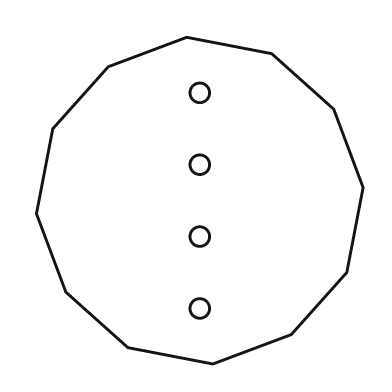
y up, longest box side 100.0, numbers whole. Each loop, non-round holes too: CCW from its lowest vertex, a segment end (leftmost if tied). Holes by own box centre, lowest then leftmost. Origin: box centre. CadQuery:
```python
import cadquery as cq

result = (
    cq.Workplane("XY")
    .moveTo(4.0, -50.0)
    .lineTo(28.0, -41.0)
    .lineTo(45.0, -22.0)
    .lineTo(50.0, 4.0)
    .lineTo(41.0, 28.0)
    .lineTo(22.0, 45.0)
    .lineTo(-4.0, 50.0)
    .lineTo(-28.0, 41.0)
    .lineTo(-45.0, 22.0)
    .lineTo(-50.0, -4.0)
    .lineTo(-41.0, -28.0)
    .lineTo(-22.0, -45.0)
    .close()
    .moveTo(0.0, -33.0)
    .circle(3.0)
    .moveTo(0.0, -11.0)
    .circle(3.0)
    .moveTo(0.0, 11.0)
    .circle(3.0)
    .moveTo(0.0, 33.0)
    .circle(3.0)
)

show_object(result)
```